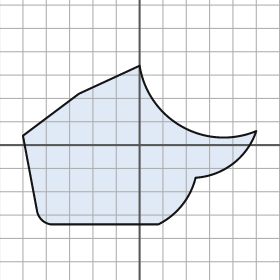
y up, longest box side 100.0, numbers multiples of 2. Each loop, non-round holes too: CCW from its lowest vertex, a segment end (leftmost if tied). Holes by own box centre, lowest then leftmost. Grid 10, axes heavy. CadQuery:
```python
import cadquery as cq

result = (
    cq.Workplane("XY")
    .moveTo(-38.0, -34.0)
    .lineTo(8.0, -34.0)
    .threePointArc((18.0, -26.0), (24.0, -14.0))
    .threePointArc((40.0, -8.0), (50.0, 6.0))
    .threePointArc((18.0, 8.0), (0.0, 34.0))
    .lineTo(-26.0, 22.0)
    .lineTo(-50.0, 4.0)
    .lineTo(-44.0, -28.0)
    .threePointArc((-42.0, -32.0), (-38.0, -34.0))
    .close()
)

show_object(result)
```